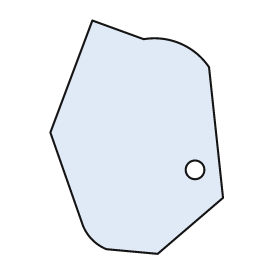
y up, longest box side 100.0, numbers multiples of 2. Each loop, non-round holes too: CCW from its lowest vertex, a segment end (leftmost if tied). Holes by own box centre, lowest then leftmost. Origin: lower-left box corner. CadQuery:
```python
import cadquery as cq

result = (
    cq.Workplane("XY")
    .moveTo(46.0, 0.0)
    .lineTo(74.0, 24.0)
    .lineTo(68.0, 80.0)
    .threePointArc((56.0, 90.0), (40.0, 92.0))
    .lineTo(18.0, 100.0)
    .lineTo(0.0, 52.0)
    .lineTo(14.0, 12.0)
    .threePointArc((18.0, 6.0), (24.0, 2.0))
    .close()
    .moveTo(62.0, 36.0)
    .circle(4.0)
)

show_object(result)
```